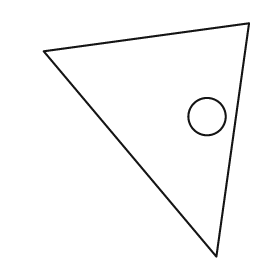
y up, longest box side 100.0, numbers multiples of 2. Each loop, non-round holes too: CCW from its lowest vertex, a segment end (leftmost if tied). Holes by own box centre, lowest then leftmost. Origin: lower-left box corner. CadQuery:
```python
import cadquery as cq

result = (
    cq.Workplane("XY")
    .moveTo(74.0, 0.0)
    .lineTo(88.0, 100.0)
    .lineTo(0.0, 88.0)
    .close()
    .moveTo(70.0, 60.0)
    .circle(8.0)
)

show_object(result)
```